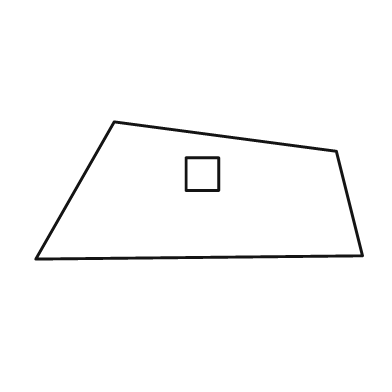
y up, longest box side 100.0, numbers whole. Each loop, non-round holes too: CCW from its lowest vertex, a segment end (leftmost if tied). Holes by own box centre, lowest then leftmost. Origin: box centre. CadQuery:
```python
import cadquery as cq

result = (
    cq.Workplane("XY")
    .moveTo(-50.0, -21.0)
    .lineTo(50.0, -20.0)
    .lineTo(42.0, 12.0)
    .lineTo(-26.0, 21.0)
    .close()
    .moveTo(-4.0, 0.0)
    .lineTo(6.0, 0.0)
    .lineTo(6.0, 10.0)
    .lineTo(-4.0, 10.0)
    .close()
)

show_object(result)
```